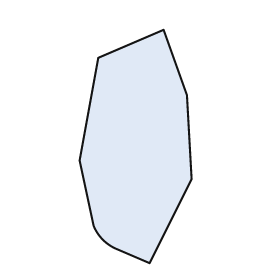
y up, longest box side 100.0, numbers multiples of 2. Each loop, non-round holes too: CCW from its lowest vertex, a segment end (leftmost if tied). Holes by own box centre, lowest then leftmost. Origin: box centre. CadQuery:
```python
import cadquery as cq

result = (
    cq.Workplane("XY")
    .moveTo(6.0, -50.0)
    .lineTo(24.0, -14.0)
    .lineTo(22.0, 22.0)
    .lineTo(12.0, 50.0)
    .lineTo(-16.0, 38.0)
    .lineTo(-24.0, -6.0)
    .lineTo(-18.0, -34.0)
    .threePointArc((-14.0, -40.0), (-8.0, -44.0))
    .close()
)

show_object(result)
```